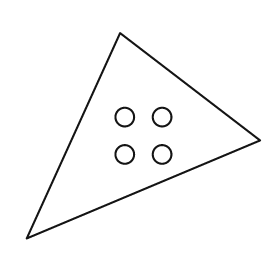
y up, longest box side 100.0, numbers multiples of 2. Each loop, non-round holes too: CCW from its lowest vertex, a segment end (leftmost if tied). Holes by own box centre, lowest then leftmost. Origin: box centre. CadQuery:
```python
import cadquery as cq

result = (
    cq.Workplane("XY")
    .moveTo(-50.0, -44.0)
    .lineTo(50.0, -2.0)
    .lineTo(-10.0, 44.0)
    .close()
    .moveTo(-8.0, -8.0)
    .circle(4.0)
    .moveTo(8.0, -8.0)
    .circle(4.0)
    .moveTo(-8.0, 8.0)
    .circle(4.0)
    .moveTo(8.0, 8.0)
    .circle(4.0)
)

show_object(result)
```